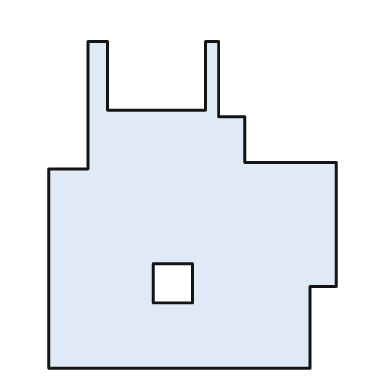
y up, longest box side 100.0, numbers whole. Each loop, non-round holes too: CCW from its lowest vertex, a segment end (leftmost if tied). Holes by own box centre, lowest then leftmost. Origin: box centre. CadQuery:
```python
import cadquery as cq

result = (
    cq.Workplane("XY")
    .moveTo(-44.0, -50.0)
    .lineTo(36.0, -50.0)
    .lineTo(36.0, -25.0)
    .lineTo(44.0, -25.0)
    .lineTo(44.0, 13.0)
    .lineTo(16.0, 13.0)
    .lineTo(16.0, 27.0)
    .lineTo(8.0, 27.0)
    .lineTo(8.0, 50.0)
    .lineTo(4.0, 50.0)
    .lineTo(4.0, 29.0)
    .lineTo(-26.0, 29.0)
    .lineTo(-26.0, 50.0)
    .lineTo(-32.0, 50.0)
    .lineTo(-32.0, 11.0)
    .lineTo(-44.0, 11.0)
    .close()
    .moveTo(-12.0, -30.0)
    .lineTo(0.0, -30.0)
    .lineTo(0.0, -18.0)
    .lineTo(-12.0, -18.0)
    .close()
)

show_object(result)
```